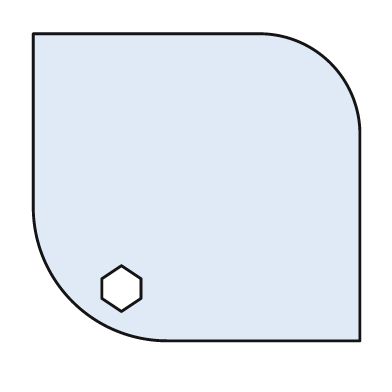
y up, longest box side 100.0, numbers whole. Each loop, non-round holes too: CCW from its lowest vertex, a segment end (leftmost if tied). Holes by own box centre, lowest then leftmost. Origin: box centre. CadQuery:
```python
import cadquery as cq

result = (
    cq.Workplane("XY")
    .moveTo(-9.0, -47.0)
    .lineTo(50.0, -47.0)
    .lineTo(50.0, 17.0)
    .threePointArc((41.0, 38.0), (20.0, 47.0))
    .lineTo(-50.0, 47.0)
    .lineTo(-50.0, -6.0)
    .threePointArc((-38.0, -35.0), (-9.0, -47.0))
    .close()
    .moveTo(-23.0, -38.0)
    .lineTo(-17.0, -34.0)
    .lineTo(-17.0, -28.0)
    .lineTo(-23.0, -24.0)
    .lineTo(-29.0, -28.0)
    .lineTo(-29.0, -34.0)
    .close()
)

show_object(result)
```